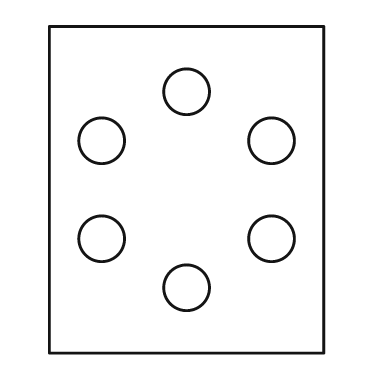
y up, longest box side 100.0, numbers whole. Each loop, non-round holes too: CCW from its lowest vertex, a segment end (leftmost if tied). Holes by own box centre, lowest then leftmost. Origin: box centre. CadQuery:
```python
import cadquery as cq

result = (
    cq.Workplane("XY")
    .moveTo(-42.0, -50.0)
    .lineTo(42.0, -50.0)
    .lineTo(42.0, 50.0)
    .lineTo(-42.0, 50.0)
    .close()
    .moveTo(0.0, -30.0)
    .circle(7.0)
    .moveTo(-26.0, -15.0)
    .circle(7.0)
    .moveTo(26.0, -15.0)
    .circle(7.0)
    .moveTo(-26.0, 15.0)
    .circle(7.0)
    .moveTo(26.0, 15.0)
    .circle(7.0)
    .moveTo(0.0, 30.0)
    .circle(7.0)
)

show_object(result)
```